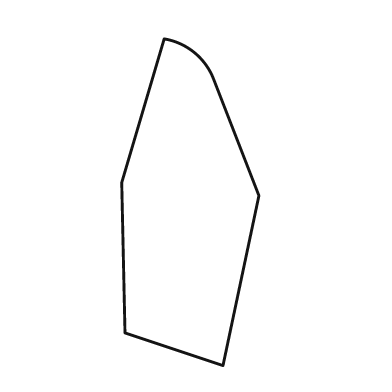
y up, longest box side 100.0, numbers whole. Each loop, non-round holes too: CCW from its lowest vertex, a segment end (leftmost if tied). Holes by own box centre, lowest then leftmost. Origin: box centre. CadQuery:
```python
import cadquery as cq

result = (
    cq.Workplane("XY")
    .moveTo(10.0, -50.0)
    .lineTo(21.0, 2.0)
    .lineTo(7.0, 38.0)
    .threePointArc((1.0, 46.0), (-8.0, 50.0))
    .lineTo(-21.0, 6.0)
    .lineTo(-20.0, -40.0)
    .close()
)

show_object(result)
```